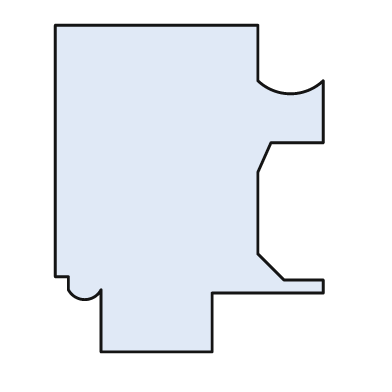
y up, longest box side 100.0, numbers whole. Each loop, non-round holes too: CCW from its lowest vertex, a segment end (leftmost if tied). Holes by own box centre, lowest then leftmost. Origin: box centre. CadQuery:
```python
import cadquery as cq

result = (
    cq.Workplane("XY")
    .moveTo(-27.0, -50.0)
    .lineTo(7.0, -50.0)
    .lineTo(7.0, -32.0)
    .lineTo(41.0, -32.0)
    .lineTo(41.0, -28.0)
    .lineTo(29.0, -28.0)
    .lineTo(21.0, -20.0)
    .lineTo(21.0, 5.0)
    .lineTo(25.0, 14.0)
    .lineTo(41.0, 14.0)
    .lineTo(41.0, 33.0)
    .threePointArc((31.0, 29.0), (21.0, 33.0))
    .lineTo(21.0, 50.0)
    .lineTo(-41.0, 50.0)
    .lineTo(-41.0, -27.0)
    .lineTo(-37.0, -27.0)
    .lineTo(-37.0, -31.0)
    .threePointArc((-32.0, -34.0), (-27.0, -31.0))
    .close()
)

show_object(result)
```